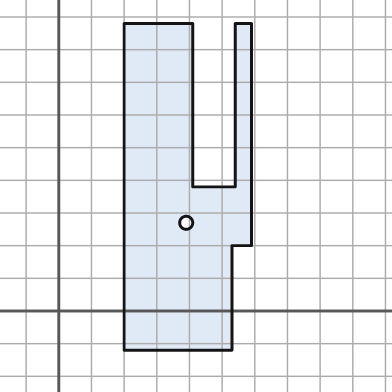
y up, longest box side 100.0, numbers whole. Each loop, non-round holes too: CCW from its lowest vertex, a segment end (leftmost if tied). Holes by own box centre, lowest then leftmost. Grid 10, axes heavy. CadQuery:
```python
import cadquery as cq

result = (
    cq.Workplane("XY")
    .moveTo(20.0, -12.0)
    .lineTo(53.0, -12.0)
    .lineTo(53.0, 20.0)
    .lineTo(59.0, 20.0)
    .lineTo(59.0, 88.0)
    .lineTo(54.0, 88.0)
    .lineTo(54.0, 38.0)
    .lineTo(41.0, 38.0)
    .lineTo(41.0, 88.0)
    .lineTo(20.0, 88.0)
    .close()
    .moveTo(39.0, 27.0)
    .circle(2.0)
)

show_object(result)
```